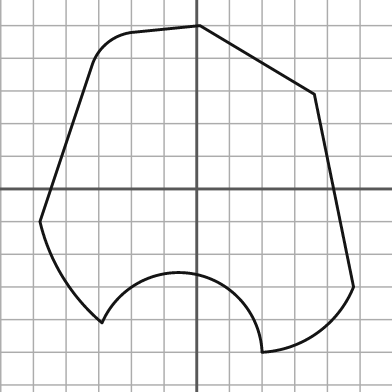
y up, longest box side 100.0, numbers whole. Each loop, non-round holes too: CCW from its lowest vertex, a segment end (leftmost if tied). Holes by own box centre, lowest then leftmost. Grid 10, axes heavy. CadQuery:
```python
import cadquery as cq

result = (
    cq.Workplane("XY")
    .moveTo(20.0, -50.0)
    .threePointArc((37.0, -44.0), (48.0, -30.0))
    .lineTo(36.0, 29.0)
    .lineTo(1.0, 50.0)
    .lineTo(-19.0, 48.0)
    .threePointArc((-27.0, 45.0), (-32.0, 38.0))
    .lineTo(-48.0, -10.0)
    .threePointArc((-41.0, -27.0), (-29.0, -41.0))
    .threePointArc((-1.0, -26.0), (20.0, -50.0))
    .close()
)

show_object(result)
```